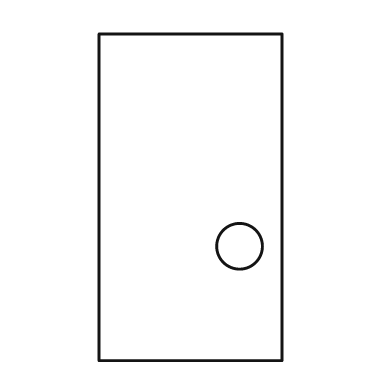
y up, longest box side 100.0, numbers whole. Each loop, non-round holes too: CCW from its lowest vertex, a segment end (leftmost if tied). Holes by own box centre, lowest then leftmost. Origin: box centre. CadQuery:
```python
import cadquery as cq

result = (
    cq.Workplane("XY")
    .moveTo(-28.0, -50.0)
    .lineTo(28.0, -50.0)
    .lineTo(28.0, 50.0)
    .lineTo(-28.0, 50.0)
    .close()
    .moveTo(15.0, -15.0)
    .circle(7.0)
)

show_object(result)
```